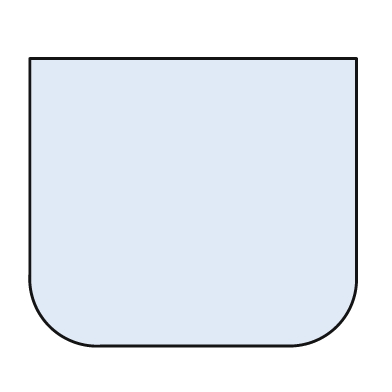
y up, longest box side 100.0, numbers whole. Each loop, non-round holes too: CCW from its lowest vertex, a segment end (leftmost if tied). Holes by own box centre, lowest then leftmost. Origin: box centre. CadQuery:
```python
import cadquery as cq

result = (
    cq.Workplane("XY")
    .moveTo(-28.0, -44.0)
    .lineTo(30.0, -44.0)
    .threePointArc((44.0, -38.0), (50.0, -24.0))
    .lineTo(50.0, 44.0)
    .lineTo(-50.0, 44.0)
    .lineTo(-50.0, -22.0)
    .threePointArc((-44.0, -38.0), (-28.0, -44.0))
    .close()
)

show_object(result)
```